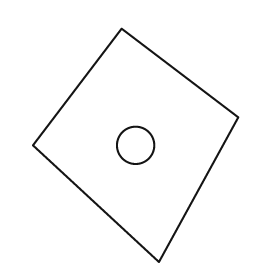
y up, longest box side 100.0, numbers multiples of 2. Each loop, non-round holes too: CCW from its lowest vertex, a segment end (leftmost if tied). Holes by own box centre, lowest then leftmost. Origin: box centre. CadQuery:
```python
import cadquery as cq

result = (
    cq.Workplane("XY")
    .moveTo(10.0, -50.0)
    .lineTo(44.0, 12.0)
    .lineTo(-6.0, 50.0)
    .lineTo(-44.0, 0.0)
    .close()
    .moveTo(0.0, 0.0)
    .circle(8.0)
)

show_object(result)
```